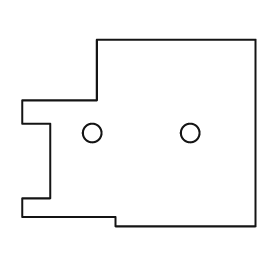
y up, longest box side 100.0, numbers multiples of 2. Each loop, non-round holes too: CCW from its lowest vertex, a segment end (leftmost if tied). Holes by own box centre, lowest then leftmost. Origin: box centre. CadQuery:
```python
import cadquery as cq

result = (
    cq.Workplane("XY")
    .moveTo(-10.0, -40.0)
    .lineTo(50.0, -40.0)
    .lineTo(50.0, 40.0)
    .lineTo(-18.0, 40.0)
    .lineTo(-18.0, 14.0)
    .lineTo(-50.0, 14.0)
    .lineTo(-50.0, 4.0)
    .lineTo(-38.0, 4.0)
    .lineTo(-38.0, -28.0)
    .lineTo(-50.0, -28.0)
    .lineTo(-50.0, -36.0)
    .lineTo(-10.0, -36.0)
    .close()
    .moveTo(-20.0, 0.0)
    .circle(4.0)
    .moveTo(22.0, 0.0)
    .circle(4.0)
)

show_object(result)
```